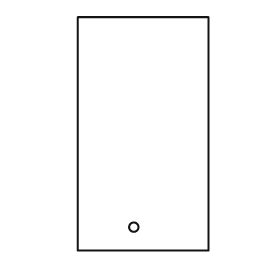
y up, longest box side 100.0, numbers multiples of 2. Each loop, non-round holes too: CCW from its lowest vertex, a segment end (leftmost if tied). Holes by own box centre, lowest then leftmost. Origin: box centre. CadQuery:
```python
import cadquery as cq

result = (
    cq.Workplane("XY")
    .moveTo(-28.0, -50.0)
    .lineTo(28.0, -50.0)
    .lineTo(28.0, 50.0)
    .lineTo(-28.0, 50.0)
    .close()
    .moveTo(-4.0, -40.0)
    .circle(2.0)
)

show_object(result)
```